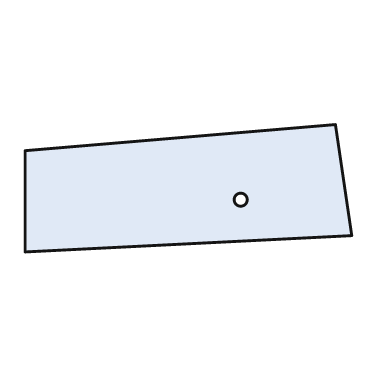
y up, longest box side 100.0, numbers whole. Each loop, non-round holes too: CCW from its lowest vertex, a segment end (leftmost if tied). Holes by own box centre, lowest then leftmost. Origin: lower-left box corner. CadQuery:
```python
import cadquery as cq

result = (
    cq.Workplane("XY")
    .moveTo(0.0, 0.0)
    .lineTo(100.0, 5.0)
    .lineTo(95.0, 39.0)
    .lineTo(0.0, 31.0)
    .close()
    .moveTo(66.0, 16.0)
    .circle(2.0)
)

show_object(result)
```